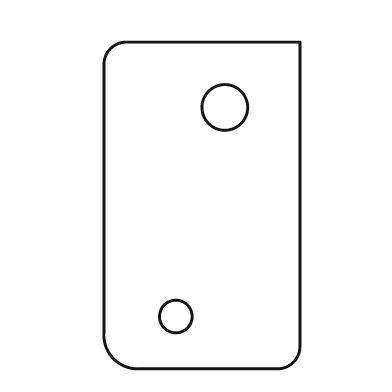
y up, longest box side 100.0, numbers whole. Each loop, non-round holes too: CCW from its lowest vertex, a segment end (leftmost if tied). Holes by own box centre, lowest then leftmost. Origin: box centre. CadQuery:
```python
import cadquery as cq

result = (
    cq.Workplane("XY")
    .moveTo(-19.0, -50.0)
    .lineTo(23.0, -50.0)
    .threePointArc((28.0, -48.0), (30.0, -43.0))
    .lineTo(30.0, 50.0)
    .lineTo(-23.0, 50.0)
    .threePointArc((-28.0, 48.0), (-30.0, 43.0))
    .lineTo(-30.0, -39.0)
    .threePointArc((-27.0, -47.0), (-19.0, -50.0))
    .close()
    .moveTo(-8.0, -34.0)
    .circle(5.0)
    .moveTo(7.0, 30.0)
    .circle(7.0)
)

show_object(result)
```